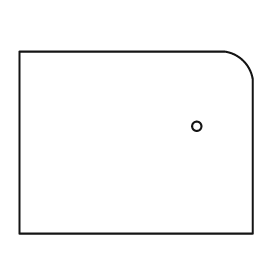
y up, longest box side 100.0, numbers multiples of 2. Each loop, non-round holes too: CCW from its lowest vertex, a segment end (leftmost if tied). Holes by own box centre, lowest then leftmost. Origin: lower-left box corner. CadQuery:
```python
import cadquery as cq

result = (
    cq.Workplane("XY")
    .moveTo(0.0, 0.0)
    .lineTo(100.0, 0.0)
    .lineTo(100.0, 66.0)
    .threePointArc((96.0, 74.0), (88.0, 78.0))
    .lineTo(0.0, 78.0)
    .close()
    .moveTo(76.0, 46.0)
    .circle(2.0)
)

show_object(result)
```